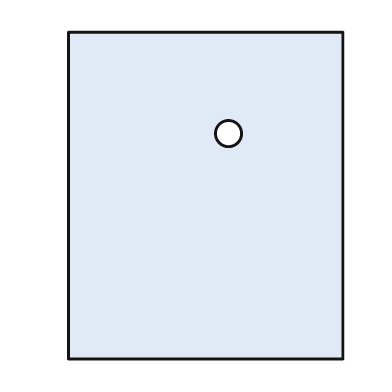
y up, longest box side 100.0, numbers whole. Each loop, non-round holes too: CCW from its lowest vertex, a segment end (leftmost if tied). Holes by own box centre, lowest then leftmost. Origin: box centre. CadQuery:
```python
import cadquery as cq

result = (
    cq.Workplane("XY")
    .moveTo(-42.0, -50.0)
    .lineTo(42.0, -50.0)
    .lineTo(42.0, 50.0)
    .lineTo(-42.0, 50.0)
    .close()
    .moveTo(7.0, 19.0)
    .circle(4.0)
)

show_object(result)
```